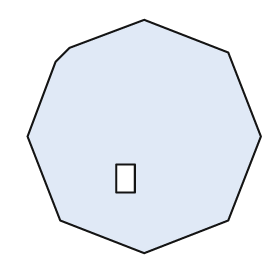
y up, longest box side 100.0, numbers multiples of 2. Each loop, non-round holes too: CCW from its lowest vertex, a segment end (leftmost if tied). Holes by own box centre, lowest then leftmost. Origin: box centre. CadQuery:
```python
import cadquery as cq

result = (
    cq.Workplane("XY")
    .moveTo(0.0, -50.0)
    .lineTo(36.0, -36.0)
    .lineTo(50.0, 0.0)
    .lineTo(36.0, 36.0)
    .lineTo(0.0, 50.0)
    .lineTo(-32.0, 38.0)
    .lineTo(-38.0, 32.0)
    .lineTo(-50.0, 0.0)
    .lineTo(-36.0, -36.0)
    .close()
    .moveTo(-12.0, -24.0)
    .lineTo(-4.0, -24.0)
    .lineTo(-4.0, -12.0)
    .lineTo(-12.0, -12.0)
    .close()
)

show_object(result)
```